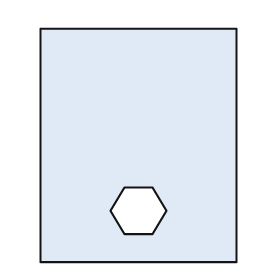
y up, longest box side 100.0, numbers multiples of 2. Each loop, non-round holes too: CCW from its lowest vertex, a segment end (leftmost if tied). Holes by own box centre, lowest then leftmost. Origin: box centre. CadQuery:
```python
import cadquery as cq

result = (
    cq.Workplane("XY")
    .moveTo(-42.0, -50.0)
    .lineTo(42.0, -50.0)
    .lineTo(42.0, 50.0)
    .lineTo(-42.0, 50.0)
    .close()
    .moveTo(-6.0, -38.0)
    .lineTo(6.0, -38.0)
    .lineTo(12.0, -28.0)
    .lineTo(6.0, -18.0)
    .lineTo(-6.0, -18.0)
    .lineTo(-12.0, -28.0)
    .close()
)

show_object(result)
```